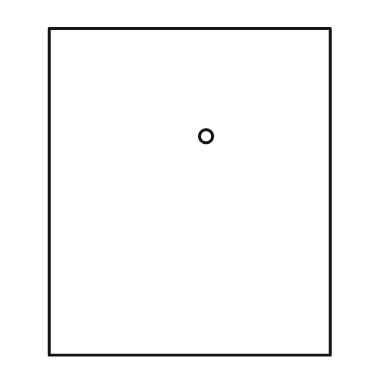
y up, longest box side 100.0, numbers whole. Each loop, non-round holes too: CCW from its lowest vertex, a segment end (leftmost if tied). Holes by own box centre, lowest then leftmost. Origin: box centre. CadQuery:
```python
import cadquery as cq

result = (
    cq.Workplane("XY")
    .moveTo(-43.0, -50.0)
    .lineTo(43.0, -50.0)
    .lineTo(43.0, 50.0)
    .lineTo(-43.0, 50.0)
    .close()
    .moveTo(5.0, 17.0)
    .circle(2.0)
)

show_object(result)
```